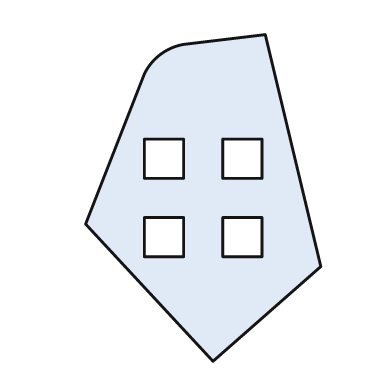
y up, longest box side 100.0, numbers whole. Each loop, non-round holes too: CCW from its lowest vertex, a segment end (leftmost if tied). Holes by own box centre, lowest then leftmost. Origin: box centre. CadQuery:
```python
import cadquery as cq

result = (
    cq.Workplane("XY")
    .moveTo(3.0, -50.0)
    .lineTo(36.0, -21.0)
    .lineTo(19.0, 50.0)
    .lineTo(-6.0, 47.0)
    .threePointArc((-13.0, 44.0), (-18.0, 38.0))
    .lineTo(-36.0, -8.0)
    .close()
    .moveTo(-18.0, -18.0)
    .lineTo(-6.0, -18.0)
    .lineTo(-6.0, -6.0)
    .lineTo(-18.0, -6.0)
    .close()
    .moveTo(6.0, -18.0)
    .lineTo(18.0, -18.0)
    .lineTo(18.0, -6.0)
    .lineTo(6.0, -6.0)
    .close()
    .moveTo(-18.0, 6.0)
    .lineTo(-6.0, 6.0)
    .lineTo(-6.0, 18.0)
    .lineTo(-18.0, 18.0)
    .close()
    .moveTo(6.0, 6.0)
    .lineTo(18.0, 6.0)
    .lineTo(18.0, 18.0)
    .lineTo(6.0, 18.0)
    .close()
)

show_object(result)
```